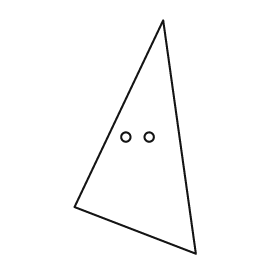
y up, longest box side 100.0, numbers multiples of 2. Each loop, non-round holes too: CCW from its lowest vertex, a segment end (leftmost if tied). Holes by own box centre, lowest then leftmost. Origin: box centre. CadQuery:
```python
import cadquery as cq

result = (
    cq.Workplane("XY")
    .moveTo(26.0, -50.0)
    .lineTo(12.0, 50.0)
    .lineTo(-26.0, -30.0)
    .close()
    .moveTo(-4.0, 0.0)
    .circle(2.0)
    .moveTo(6.0, 0.0)
    .circle(2.0)
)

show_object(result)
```